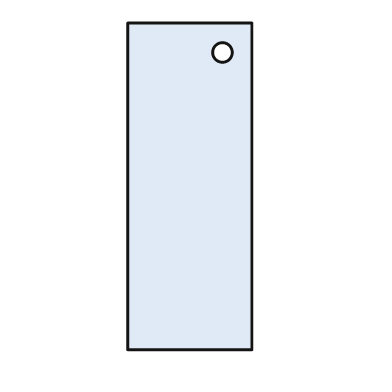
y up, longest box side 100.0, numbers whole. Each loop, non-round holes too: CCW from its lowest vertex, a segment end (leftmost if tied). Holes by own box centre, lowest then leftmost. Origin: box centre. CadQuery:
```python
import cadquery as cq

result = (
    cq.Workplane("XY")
    .moveTo(-19.0, -50.0)
    .lineTo(19.0, -50.0)
    .lineTo(19.0, 50.0)
    .lineTo(-19.0, 50.0)
    .close()
    .moveTo(10.0, 41.0)
    .circle(3.0)
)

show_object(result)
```